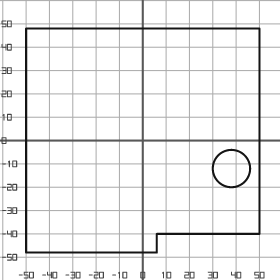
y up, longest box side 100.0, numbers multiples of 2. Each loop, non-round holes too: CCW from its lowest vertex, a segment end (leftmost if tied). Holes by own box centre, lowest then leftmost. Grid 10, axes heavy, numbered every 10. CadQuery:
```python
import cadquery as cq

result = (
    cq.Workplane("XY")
    .moveTo(-50.0, -48.0)
    .lineTo(6.0, -48.0)
    .lineTo(6.0, -40.0)
    .lineTo(50.0, -40.0)
    .lineTo(50.0, 48.0)
    .lineTo(-50.0, 48.0)
    .close()
    .moveTo(38.0, -12.0)
    .circle(8.0)
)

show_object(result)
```